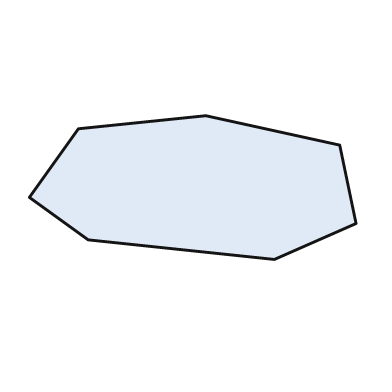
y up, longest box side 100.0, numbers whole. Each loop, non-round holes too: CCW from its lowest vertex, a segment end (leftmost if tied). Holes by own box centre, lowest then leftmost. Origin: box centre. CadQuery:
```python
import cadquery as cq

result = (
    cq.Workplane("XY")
    .moveTo(25.0, -22.0)
    .lineTo(50.0, -11.0)
    .lineTo(45.0, 13.0)
    .lineTo(4.0, 22.0)
    .lineTo(-35.0, 18.0)
    .lineTo(-50.0, -3.0)
    .lineTo(-32.0, -16.0)
    .close()
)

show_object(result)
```